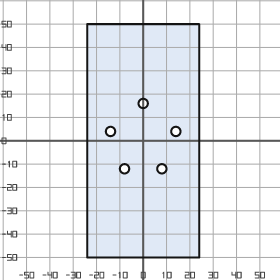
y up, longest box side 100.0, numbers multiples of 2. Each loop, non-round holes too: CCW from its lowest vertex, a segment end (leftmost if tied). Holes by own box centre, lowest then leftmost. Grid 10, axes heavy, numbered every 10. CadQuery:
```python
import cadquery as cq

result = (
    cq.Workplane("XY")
    .moveTo(-24.0, -50.0)
    .lineTo(24.0, -50.0)
    .lineTo(24.0, 50.0)
    .lineTo(-24.0, 50.0)
    .close()
    .moveTo(-8.0, -12.0)
    .circle(2.0)
    .moveTo(8.0, -12.0)
    .circle(2.0)
    .moveTo(-14.0, 4.0)
    .circle(2.0)
    .moveTo(14.0, 4.0)
    .circle(2.0)
    .moveTo(0.0, 16.0)
    .circle(2.0)
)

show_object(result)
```